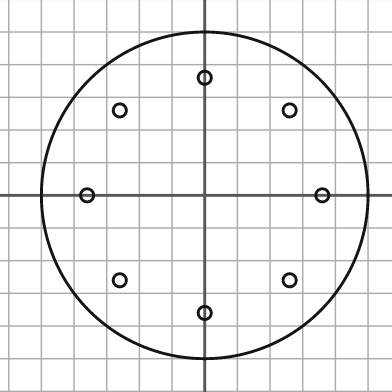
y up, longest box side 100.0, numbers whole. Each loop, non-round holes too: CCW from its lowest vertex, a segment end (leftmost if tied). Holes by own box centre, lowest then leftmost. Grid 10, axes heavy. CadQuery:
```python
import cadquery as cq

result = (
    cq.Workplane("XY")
    .moveTo(0.0, 0.0)
    .circle(50.0)
    .moveTo(0.0, -36.0)
    .circle(2.0)
    .moveTo(-26.0, -26.0)
    .circle(2.0)
    .moveTo(26.0, -26.0)
    .circle(2.0)
    .moveTo(-36.0, 0.0)
    .circle(2.0)
    .moveTo(36.0, 0.0)
    .circle(2.0)
    .moveTo(-26.0, 26.0)
    .circle(2.0)
    .moveTo(26.0, 26.0)
    .circle(2.0)
    .moveTo(0.0, 36.0)
    .circle(2.0)
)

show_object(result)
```